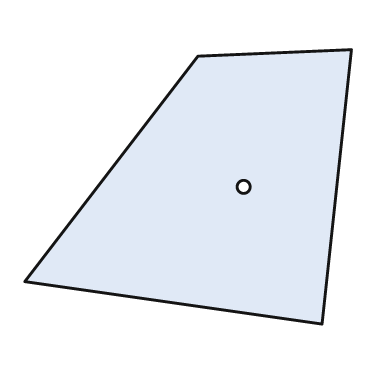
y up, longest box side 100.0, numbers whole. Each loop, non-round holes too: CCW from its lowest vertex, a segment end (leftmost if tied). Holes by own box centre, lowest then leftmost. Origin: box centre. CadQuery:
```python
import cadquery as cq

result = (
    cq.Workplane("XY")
    .moveTo(41.0, -42.0)
    .lineTo(50.0, 42.0)
    .lineTo(3.0, 40.0)
    .lineTo(-50.0, -29.0)
    .close()
    .moveTo(17.0, 0.0)
    .circle(2.0)
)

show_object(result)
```